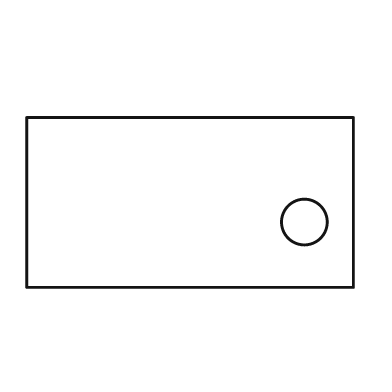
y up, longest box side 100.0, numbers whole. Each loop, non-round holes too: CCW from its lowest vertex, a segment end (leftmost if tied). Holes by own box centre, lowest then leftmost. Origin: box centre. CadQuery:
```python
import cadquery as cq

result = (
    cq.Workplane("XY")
    .moveTo(-50.0, -26.0)
    .lineTo(50.0, -26.0)
    .lineTo(50.0, 26.0)
    .lineTo(-50.0, 26.0)
    .close()
    .moveTo(35.0, -6.0)
    .circle(7.0)
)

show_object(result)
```